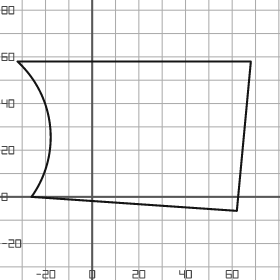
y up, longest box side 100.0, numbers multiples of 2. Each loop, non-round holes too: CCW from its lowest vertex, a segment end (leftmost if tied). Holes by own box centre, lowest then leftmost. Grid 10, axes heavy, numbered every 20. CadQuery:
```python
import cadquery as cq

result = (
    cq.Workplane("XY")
    .moveTo(62.0, -6.0)
    .lineTo(68.0, 58.0)
    .lineTo(-32.0, 58.0)
    .threePointArc((-18.0, 30.0), (-26.0, 0.0))
    .close()
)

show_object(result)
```